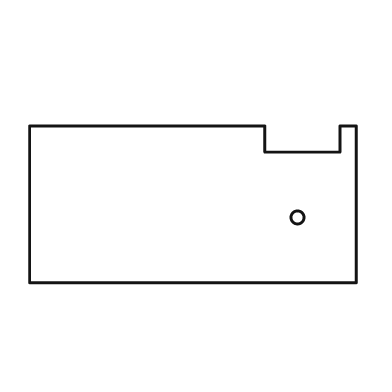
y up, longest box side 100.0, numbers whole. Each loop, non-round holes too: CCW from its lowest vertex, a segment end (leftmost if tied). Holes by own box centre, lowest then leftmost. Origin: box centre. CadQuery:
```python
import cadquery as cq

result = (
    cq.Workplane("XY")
    .moveTo(-50.0, -24.0)
    .lineTo(50.0, -24.0)
    .lineTo(50.0, 24.0)
    .lineTo(45.0, 24.0)
    .lineTo(45.0, 16.0)
    .lineTo(22.0, 16.0)
    .lineTo(22.0, 24.0)
    .lineTo(-50.0, 24.0)
    .close()
    .moveTo(32.0, -4.0)
    .circle(2.0)
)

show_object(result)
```